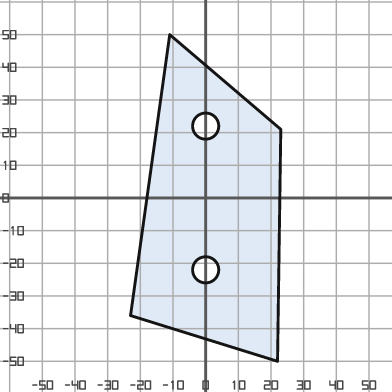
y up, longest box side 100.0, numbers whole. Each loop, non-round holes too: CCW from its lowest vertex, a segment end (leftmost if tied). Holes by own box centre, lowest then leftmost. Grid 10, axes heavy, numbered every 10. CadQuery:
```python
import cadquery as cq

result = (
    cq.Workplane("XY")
    .moveTo(22.0, -50.0)
    .lineTo(23.0, 21.0)
    .lineTo(-11.0, 50.0)
    .lineTo(-23.0, -36.0)
    .close()
    .moveTo(0.0, -22.0)
    .circle(4.0)
    .moveTo(0.0, 22.0)
    .circle(4.0)
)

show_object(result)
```